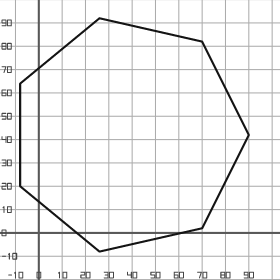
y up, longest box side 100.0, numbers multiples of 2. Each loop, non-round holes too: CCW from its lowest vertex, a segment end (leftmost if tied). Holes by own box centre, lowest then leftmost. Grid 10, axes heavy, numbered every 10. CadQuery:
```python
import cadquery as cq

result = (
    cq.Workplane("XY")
    .moveTo(26.0, -8.0)
    .lineTo(70.0, 2.0)
    .lineTo(90.0, 42.0)
    .lineTo(70.0, 82.0)
    .lineTo(26.0, 92.0)
    .lineTo(-8.0, 64.0)
    .lineTo(-8.0, 20.0)
    .close()
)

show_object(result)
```